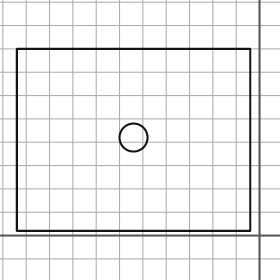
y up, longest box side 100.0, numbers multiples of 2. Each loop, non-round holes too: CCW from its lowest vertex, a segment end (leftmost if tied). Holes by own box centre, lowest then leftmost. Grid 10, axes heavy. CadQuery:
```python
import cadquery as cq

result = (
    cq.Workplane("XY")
    .moveTo(-104.0, 2.0)
    .lineTo(-4.0, 2.0)
    .lineTo(-4.0, 80.0)
    .lineTo(-104.0, 80.0)
    .close()
    .moveTo(-54.0, 42.0)
    .circle(6.0)
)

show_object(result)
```